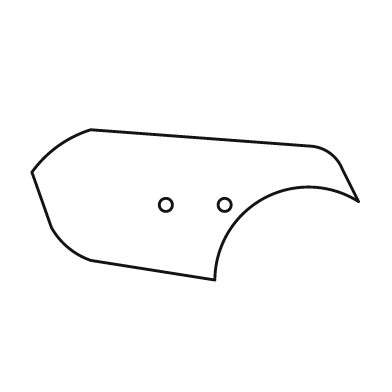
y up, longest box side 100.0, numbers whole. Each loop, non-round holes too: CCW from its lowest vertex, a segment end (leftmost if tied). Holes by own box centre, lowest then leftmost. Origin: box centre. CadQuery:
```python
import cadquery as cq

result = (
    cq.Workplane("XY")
    .moveTo(6.0, -23.0)
    .threePointArc((21.0, 2.0), (50.0, 1.0))
    .lineTo(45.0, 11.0)
    .threePointArc((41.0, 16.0), (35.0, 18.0))
    .lineTo(-32.0, 23.0)
    .threePointArc((-42.0, 18.0), (-50.0, 10.0))
    .lineTo(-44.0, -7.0)
    .threePointArc((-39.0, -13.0), (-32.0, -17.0))
    .close()
    .moveTo(-9.0, 0.0)
    .circle(2.0)
    .moveTo(9.0, 0.0)
    .circle(2.0)
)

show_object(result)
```